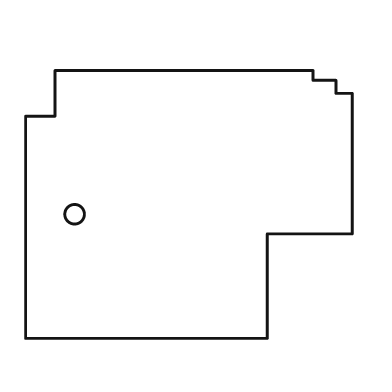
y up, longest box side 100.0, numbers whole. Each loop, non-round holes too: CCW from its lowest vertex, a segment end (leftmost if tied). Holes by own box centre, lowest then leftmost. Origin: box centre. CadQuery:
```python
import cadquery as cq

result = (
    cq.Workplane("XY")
    .moveTo(-50.0, -41.0)
    .lineTo(24.0, -41.0)
    .lineTo(24.0, -9.0)
    .lineTo(50.0, -9.0)
    .lineTo(50.0, 34.0)
    .lineTo(45.0, 34.0)
    .lineTo(45.0, 38.0)
    .lineTo(38.0, 38.0)
    .lineTo(38.0, 41.0)
    .lineTo(-41.0, 41.0)
    .lineTo(-41.0, 27.0)
    .lineTo(-50.0, 27.0)
    .close()
    .moveTo(-35.0, -3.0)
    .circle(3.0)
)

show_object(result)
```